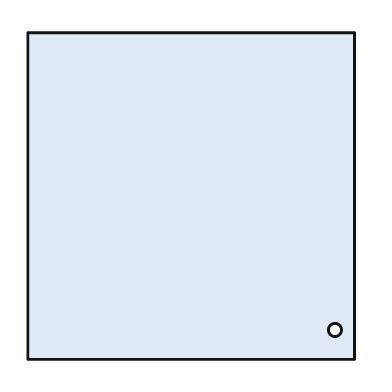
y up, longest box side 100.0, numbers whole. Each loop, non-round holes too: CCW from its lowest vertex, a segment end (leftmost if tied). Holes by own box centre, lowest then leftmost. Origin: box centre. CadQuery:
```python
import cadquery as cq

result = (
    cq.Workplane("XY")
    .moveTo(-50.0, -50.0)
    .lineTo(50.0, -50.0)
    .lineTo(50.0, 50.0)
    .lineTo(-50.0, 50.0)
    .close()
    .moveTo(44.0, -41.0)
    .circle(2.0)
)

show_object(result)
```